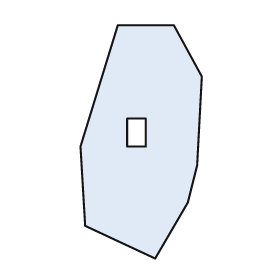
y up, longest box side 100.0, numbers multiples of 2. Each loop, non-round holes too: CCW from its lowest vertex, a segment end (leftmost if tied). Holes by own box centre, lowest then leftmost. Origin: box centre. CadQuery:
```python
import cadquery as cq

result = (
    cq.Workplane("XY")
    .moveTo(6.0, -50.0)
    .lineTo(20.0, -26.0)
    .lineTo(24.0, -10.0)
    .lineTo(26.0, 28.0)
    .lineTo(14.0, 50.0)
    .lineTo(-10.0, 50.0)
    .lineTo(-26.0, -2.0)
    .lineTo(-24.0, -36.0)
    .close()
    .moveTo(-6.0, -2.0)
    .lineTo(2.0, -2.0)
    .lineTo(2.0, 10.0)
    .lineTo(-6.0, 10.0)
    .close()
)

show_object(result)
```